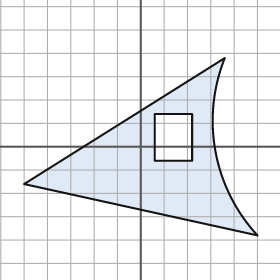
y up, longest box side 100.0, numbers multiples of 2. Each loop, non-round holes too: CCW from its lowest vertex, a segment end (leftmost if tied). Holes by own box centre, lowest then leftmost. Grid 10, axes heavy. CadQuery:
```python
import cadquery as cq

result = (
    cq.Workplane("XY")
    .moveTo(50.0, -38.0)
    .threePointArc((32.0, -2.0), (36.0, 38.0))
    .lineTo(-50.0, -16.0)
    .close()
    .moveTo(6.0, -6.0)
    .lineTo(22.0, -6.0)
    .lineTo(22.0, 14.0)
    .lineTo(6.0, 14.0)
    .close()
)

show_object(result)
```